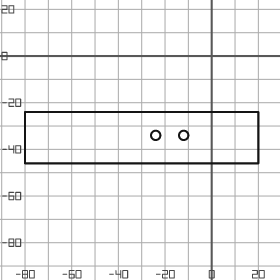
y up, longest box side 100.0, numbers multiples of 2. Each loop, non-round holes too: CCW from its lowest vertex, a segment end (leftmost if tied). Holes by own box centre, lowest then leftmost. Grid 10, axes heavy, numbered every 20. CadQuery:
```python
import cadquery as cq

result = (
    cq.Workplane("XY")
    .moveTo(-80.0, -46.0)
    .lineTo(20.0, -46.0)
    .lineTo(20.0, -24.0)
    .lineTo(-80.0, -24.0)
    .close()
    .moveTo(-24.0, -34.0)
    .circle(2.0)
    .moveTo(-12.0, -34.0)
    .circle(2.0)
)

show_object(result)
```